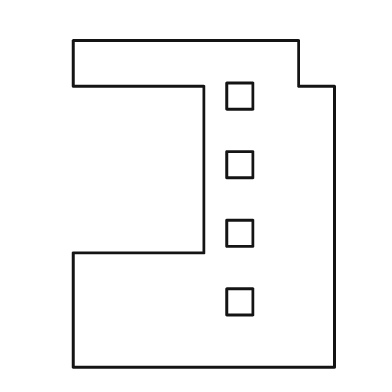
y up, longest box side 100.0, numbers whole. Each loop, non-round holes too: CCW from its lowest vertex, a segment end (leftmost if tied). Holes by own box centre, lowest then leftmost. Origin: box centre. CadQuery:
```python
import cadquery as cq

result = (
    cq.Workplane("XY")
    .moveTo(-40.0, -50.0)
    .lineTo(40.0, -50.0)
    .lineTo(40.0, 36.0)
    .lineTo(29.0, 36.0)
    .lineTo(29.0, 50.0)
    .lineTo(-40.0, 50.0)
    .lineTo(-40.0, 36.0)
    .lineTo(0.0, 36.0)
    .lineTo(0.0, -15.0)
    .lineTo(-40.0, -15.0)
    .close()
    .moveTo(7.0, -34.0)
    .lineTo(15.0, -34.0)
    .lineTo(15.0, -26.0)
    .lineTo(7.0, -26.0)
    .close()
    .moveTo(7.0, -13.0)
    .lineTo(15.0, -13.0)
    .lineTo(15.0, -5.0)
    .lineTo(7.0, -5.0)
    .close()
    .moveTo(7.0, 8.0)
    .lineTo(15.0, 8.0)
    .lineTo(15.0, 16.0)
    .lineTo(7.0, 16.0)
    .close()
    .moveTo(7.0, 29.0)
    .lineTo(15.0, 29.0)
    .lineTo(15.0, 37.0)
    .lineTo(7.0, 37.0)
    .close()
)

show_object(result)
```